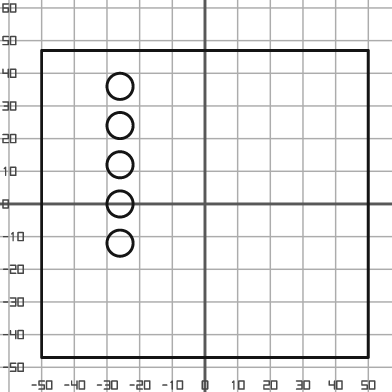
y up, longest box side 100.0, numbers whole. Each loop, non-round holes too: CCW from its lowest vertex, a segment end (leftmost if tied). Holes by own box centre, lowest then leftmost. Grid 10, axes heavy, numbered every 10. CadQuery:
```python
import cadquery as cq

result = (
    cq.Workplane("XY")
    .moveTo(-50.0, -47.0)
    .lineTo(50.0, -47.0)
    .lineTo(50.0, 47.0)
    .lineTo(-50.0, 47.0)
    .close()
    .moveTo(-26.0, -12.0)
    .circle(4.0)
    .moveTo(-26.0, 0.0)
    .circle(4.0)
    .moveTo(-26.0, 12.0)
    .circle(4.0)
    .moveTo(-26.0, 24.0)
    .circle(4.0)
    .moveTo(-26.0, 36.0)
    .circle(4.0)
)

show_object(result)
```